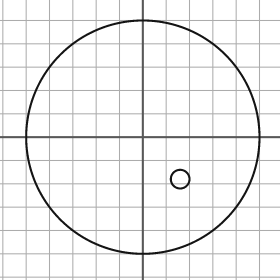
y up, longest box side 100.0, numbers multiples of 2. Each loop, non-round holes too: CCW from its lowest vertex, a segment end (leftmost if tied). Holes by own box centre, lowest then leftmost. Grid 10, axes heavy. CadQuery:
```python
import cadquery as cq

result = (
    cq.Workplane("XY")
    .moveTo(0.0, 0.0)
    .circle(50.0)
    .moveTo(16.0, -18.0)
    .circle(4.0)
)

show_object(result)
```